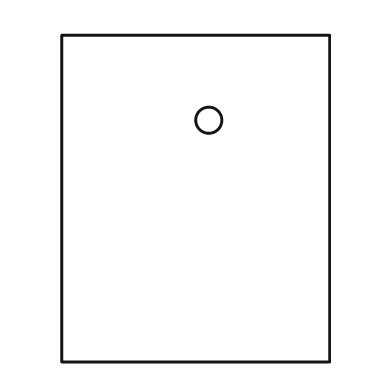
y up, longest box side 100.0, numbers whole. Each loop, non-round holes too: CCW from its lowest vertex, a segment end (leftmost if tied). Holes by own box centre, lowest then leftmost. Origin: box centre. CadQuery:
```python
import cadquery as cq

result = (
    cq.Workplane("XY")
    .moveTo(-41.0, -50.0)
    .lineTo(41.0, -50.0)
    .lineTo(41.0, 50.0)
    .lineTo(-41.0, 50.0)
    .close()
    .moveTo(4.0, 24.0)
    .circle(4.0)
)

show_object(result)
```